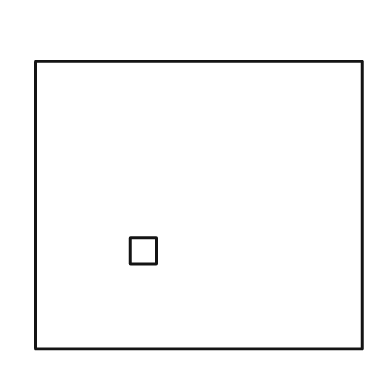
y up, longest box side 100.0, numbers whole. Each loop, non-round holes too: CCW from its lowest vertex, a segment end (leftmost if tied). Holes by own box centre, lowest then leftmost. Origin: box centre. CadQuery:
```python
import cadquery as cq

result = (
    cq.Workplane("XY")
    .moveTo(-50.0, -44.0)
    .lineTo(50.0, -44.0)
    .lineTo(50.0, 44.0)
    .lineTo(-50.0, 44.0)
    .close()
    .moveTo(-21.0, -18.0)
    .lineTo(-13.0, -18.0)
    .lineTo(-13.0, -10.0)
    .lineTo(-21.0, -10.0)
    .close()
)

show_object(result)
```